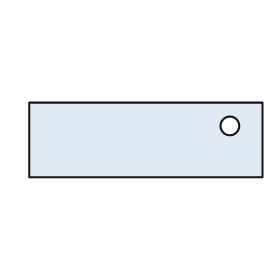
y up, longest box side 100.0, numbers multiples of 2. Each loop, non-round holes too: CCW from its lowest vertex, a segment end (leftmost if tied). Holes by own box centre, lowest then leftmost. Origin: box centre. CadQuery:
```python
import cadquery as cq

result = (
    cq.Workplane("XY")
    .moveTo(-50.0, -16.0)
    .lineTo(50.0, -16.0)
    .lineTo(50.0, 16.0)
    .lineTo(-50.0, 16.0)
    .close()
    .moveTo(36.0, 6.0)
    .circle(4.0)
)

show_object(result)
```